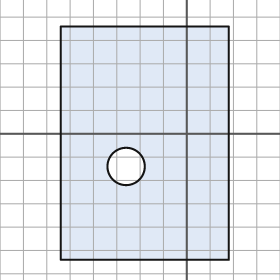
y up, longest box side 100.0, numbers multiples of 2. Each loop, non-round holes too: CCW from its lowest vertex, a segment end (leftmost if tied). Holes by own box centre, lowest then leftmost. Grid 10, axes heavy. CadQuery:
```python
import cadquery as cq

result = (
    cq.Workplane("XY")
    .moveTo(-54.0, -54.0)
    .lineTo(18.0, -54.0)
    .lineTo(18.0, 46.0)
    .lineTo(-54.0, 46.0)
    .close()
    .moveTo(-26.0, -14.0)
    .circle(8.0)
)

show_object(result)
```